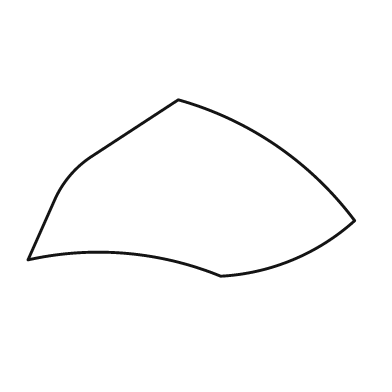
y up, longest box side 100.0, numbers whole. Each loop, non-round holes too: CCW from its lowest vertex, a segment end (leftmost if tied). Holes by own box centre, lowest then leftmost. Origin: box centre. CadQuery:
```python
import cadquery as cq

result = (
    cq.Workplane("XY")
    .moveTo(9.0, -27.0)
    .threePointArc((31.0, -22.0), (50.0, -10.0))
    .threePointArc((26.0, 13.0), (-4.0, 27.0))
    .lineTo(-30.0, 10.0)
    .threePointArc((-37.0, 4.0), (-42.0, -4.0))
    .lineTo(-50.0, -22.0)
    .threePointArc((-20.0, -20.0), (9.0, -27.0))
    .close()
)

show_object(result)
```